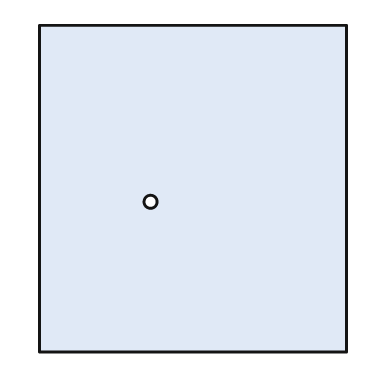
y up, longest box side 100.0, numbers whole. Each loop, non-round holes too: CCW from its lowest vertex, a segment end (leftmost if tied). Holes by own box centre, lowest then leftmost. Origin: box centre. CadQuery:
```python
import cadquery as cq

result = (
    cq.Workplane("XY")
    .moveTo(-47.0, -50.0)
    .lineTo(47.0, -50.0)
    .lineTo(47.0, 50.0)
    .lineTo(-47.0, 50.0)
    .close()
    .moveTo(-13.0, -4.0)
    .circle(2.0)
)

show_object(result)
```